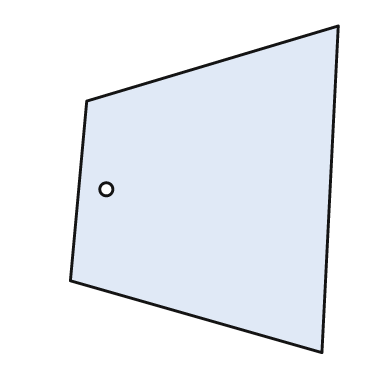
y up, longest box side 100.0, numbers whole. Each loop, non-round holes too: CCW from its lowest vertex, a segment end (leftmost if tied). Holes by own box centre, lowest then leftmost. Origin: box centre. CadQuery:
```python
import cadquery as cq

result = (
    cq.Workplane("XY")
    .moveTo(36.0, -50.0)
    .lineTo(41.0, 50.0)
    .lineTo(-36.0, 27.0)
    .lineTo(-41.0, -28.0)
    .close()
    .moveTo(-30.0, 0.0)
    .circle(2.0)
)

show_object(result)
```